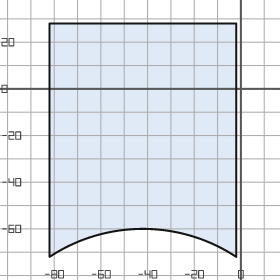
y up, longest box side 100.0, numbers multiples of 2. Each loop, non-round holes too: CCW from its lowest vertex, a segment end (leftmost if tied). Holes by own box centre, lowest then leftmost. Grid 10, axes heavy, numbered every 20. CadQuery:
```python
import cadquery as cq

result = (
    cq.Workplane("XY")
    .moveTo(-82.0, -72.0)
    .threePointArc((-42.0, -60.0), (-2.0, -72.0))
    .lineTo(-2.0, 28.0)
    .lineTo(-82.0, 28.0)
    .close()
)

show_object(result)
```